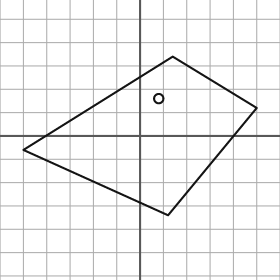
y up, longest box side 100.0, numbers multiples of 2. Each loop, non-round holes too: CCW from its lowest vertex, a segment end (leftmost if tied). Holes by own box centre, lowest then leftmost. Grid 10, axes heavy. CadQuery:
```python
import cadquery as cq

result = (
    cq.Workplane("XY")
    .moveTo(12.0, -34.0)
    .lineTo(50.0, 12.0)
    .lineTo(14.0, 34.0)
    .lineTo(-50.0, -6.0)
    .close()
    .moveTo(8.0, 16.0)
    .circle(2.0)
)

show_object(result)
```